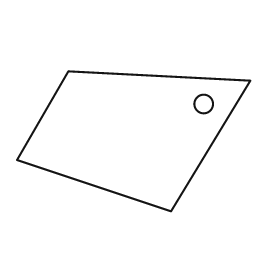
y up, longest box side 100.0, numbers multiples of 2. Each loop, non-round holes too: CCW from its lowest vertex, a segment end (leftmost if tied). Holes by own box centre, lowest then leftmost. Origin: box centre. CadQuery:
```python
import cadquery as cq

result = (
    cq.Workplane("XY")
    .moveTo(16.0, -30.0)
    .lineTo(50.0, 26.0)
    .lineTo(-28.0, 30.0)
    .lineTo(-50.0, -8.0)
    .close()
    .moveTo(30.0, 16.0)
    .circle(4.0)
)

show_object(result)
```